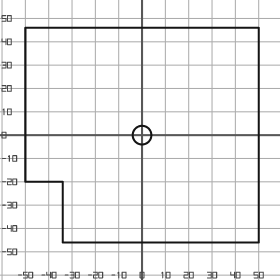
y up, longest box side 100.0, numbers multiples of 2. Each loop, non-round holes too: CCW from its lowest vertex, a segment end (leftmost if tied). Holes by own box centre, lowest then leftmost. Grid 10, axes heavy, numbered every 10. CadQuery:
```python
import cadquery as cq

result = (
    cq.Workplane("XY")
    .moveTo(-34.0, -46.0)
    .lineTo(50.0, -46.0)
    .lineTo(50.0, 46.0)
    .lineTo(-50.0, 46.0)
    .lineTo(-50.0, -20.0)
    .lineTo(-34.0, -20.0)
    .close()
    .moveTo(0.0, 0.0)
    .circle(4.0)
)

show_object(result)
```